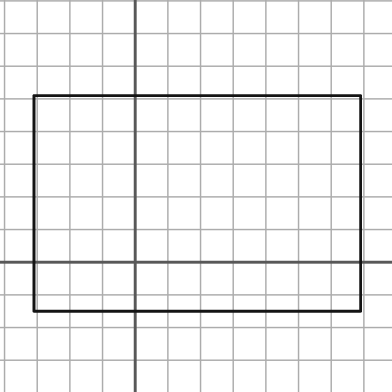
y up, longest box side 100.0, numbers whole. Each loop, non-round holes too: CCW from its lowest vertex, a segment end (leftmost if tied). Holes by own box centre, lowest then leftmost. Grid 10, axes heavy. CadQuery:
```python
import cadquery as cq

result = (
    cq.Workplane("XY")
    .moveTo(-31.0, -15.0)
    .lineTo(69.0, -15.0)
    .lineTo(69.0, 51.0)
    .lineTo(-31.0, 51.0)
    .close()
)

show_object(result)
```